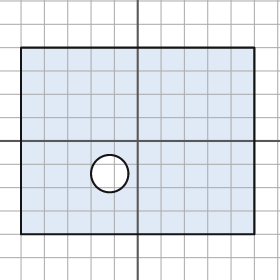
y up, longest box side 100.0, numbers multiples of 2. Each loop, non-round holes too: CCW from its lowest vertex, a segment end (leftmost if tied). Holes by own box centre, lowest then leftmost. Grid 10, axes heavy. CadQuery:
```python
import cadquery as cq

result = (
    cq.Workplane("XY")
    .moveTo(-50.0, -40.0)
    .lineTo(50.0, -40.0)
    .lineTo(50.0, 40.0)
    .lineTo(-50.0, 40.0)
    .close()
    .moveTo(-12.0, -14.0)
    .circle(8.0)
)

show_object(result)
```